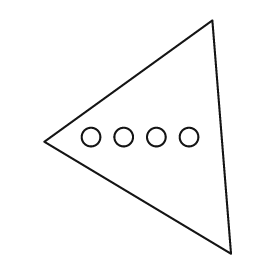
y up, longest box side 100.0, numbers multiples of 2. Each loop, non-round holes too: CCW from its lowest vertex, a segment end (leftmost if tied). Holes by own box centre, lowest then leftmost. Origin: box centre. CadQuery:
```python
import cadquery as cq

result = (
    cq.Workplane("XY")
    .moveTo(40.0, -50.0)
    .lineTo(32.0, 50.0)
    .lineTo(-40.0, -2.0)
    .close()
    .moveTo(-20.0, 0.0)
    .circle(4.0)
    .moveTo(-6.0, 0.0)
    .circle(4.0)
    .moveTo(8.0, 0.0)
    .circle(4.0)
    .moveTo(22.0, 0.0)
    .circle(4.0)
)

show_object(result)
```